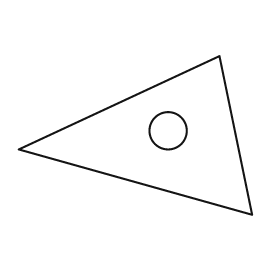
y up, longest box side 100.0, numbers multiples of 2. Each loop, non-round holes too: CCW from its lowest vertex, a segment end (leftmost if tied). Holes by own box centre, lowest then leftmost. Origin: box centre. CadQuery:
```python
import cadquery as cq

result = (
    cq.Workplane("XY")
    .moveTo(50.0, -34.0)
    .lineTo(36.0, 34.0)
    .lineTo(-50.0, -6.0)
    .close()
    .moveTo(14.0, 2.0)
    .circle(8.0)
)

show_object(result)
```